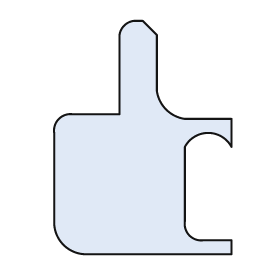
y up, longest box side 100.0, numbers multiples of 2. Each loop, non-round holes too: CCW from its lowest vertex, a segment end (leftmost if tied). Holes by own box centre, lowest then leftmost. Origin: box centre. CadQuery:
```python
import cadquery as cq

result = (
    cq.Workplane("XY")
    .moveTo(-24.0, -50.0)
    .lineTo(38.0, -50.0)
    .lineTo(38.0, -44.0)
    .lineTo(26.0, -44.0)
    .threePointArc((20.0, -42.0), (18.0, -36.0))
    .lineTo(18.0, -4.0)
    .threePointArc((28.0, 2.0), (38.0, -4.0))
    .lineTo(38.0, 8.0)
    .lineTo(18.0, 8.0)
    .threePointArc((10.0, 12.0), (6.0, 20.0))
    .lineTo(6.0, 44.0)
    .lineTo(0.0, 50.0)
    .lineTo(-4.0, 50.0)
    .threePointArc((-8.0, 48.0), (-10.0, 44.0))
    .lineTo(-10.0, 10.0)
    .lineTo(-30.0, 10.0)
    .threePointArc((-36.0, 8.0), (-38.0, 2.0))
    .lineTo(-38.0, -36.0)
    .threePointArc((-34.0, -46.0), (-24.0, -50.0))
    .close()
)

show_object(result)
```